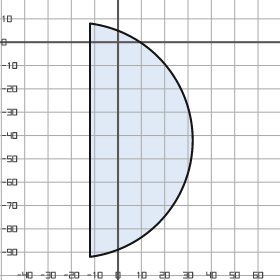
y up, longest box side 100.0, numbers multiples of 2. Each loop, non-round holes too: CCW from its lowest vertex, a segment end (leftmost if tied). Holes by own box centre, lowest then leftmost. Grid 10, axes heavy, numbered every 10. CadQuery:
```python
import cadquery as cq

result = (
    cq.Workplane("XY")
    .moveTo(-12.0, -92.0)
    .threePointArc((32.0, -42.0), (-12.0, 8.0))
    .close()
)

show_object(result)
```